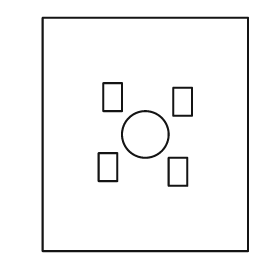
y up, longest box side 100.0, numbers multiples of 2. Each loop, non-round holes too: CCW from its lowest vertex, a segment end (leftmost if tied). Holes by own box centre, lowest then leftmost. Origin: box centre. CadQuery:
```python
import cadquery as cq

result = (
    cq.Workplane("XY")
    .moveTo(-44.0, -50.0)
    .lineTo(44.0, -50.0)
    .lineTo(44.0, 50.0)
    .lineTo(-44.0, 50.0)
    .close()
    .moveTo(10.0, -22.0)
    .lineTo(18.0, -22.0)
    .lineTo(18.0, -10.0)
    .lineTo(10.0, -10.0)
    .close()
    .moveTo(-20.0, -20.0)
    .lineTo(-12.0, -20.0)
    .lineTo(-12.0, -8.0)
    .lineTo(-20.0, -8.0)
    .close()
    .moveTo(0.0, 0.0)
    .circle(10.0)
    .moveTo(12.0, 8.0)
    .lineTo(20.0, 8.0)
    .lineTo(20.0, 20.0)
    .lineTo(12.0, 20.0)
    .close()
    .moveTo(-18.0, 10.0)
    .lineTo(-10.0, 10.0)
    .lineTo(-10.0, 22.0)
    .lineTo(-18.0, 22.0)
    .close()
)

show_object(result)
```